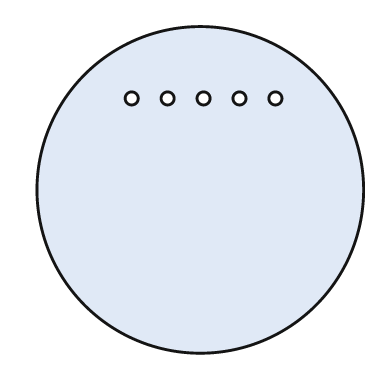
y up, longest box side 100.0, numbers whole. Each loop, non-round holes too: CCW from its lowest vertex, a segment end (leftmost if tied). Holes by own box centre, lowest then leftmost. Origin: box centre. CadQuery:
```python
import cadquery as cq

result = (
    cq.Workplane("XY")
    .moveTo(0.0, 0.0)
    .circle(50.0)
    .moveTo(-21.0, 28.0)
    .circle(2.0)
    .moveTo(-10.0, 28.0)
    .circle(2.0)
    .moveTo(1.0, 28.0)
    .circle(2.0)
    .moveTo(12.0, 28.0)
    .circle(2.0)
    .moveTo(23.0, 28.0)
    .circle(2.0)
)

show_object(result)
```